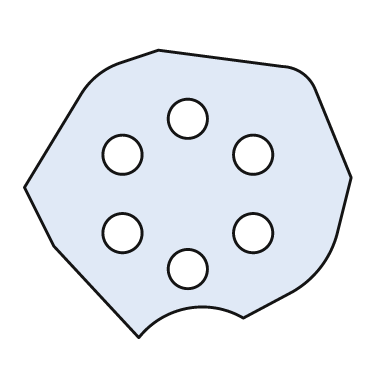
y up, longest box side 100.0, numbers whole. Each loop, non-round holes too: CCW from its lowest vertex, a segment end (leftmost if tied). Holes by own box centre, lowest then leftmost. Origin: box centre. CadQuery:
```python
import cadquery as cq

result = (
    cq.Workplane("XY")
    .moveTo(-15.0, -44.0)
    .threePointArc((0.0, -35.0), (17.0, -38.0))
    .lineTo(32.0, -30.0)
    .threePointArc((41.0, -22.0), (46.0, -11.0))
    .lineTo(50.0, 5.0)
    .lineTo(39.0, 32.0)
    .threePointArc((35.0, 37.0), (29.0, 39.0))
    .lineTo(-9.0, 44.0)
    .lineTo(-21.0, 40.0)
    .threePointArc((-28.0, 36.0), (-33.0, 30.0))
    .lineTo(-50.0, 2.0)
    .lineTo(-41.0, -16.0)
    .close()
    .moveTo(0.0, -23.0)
    .circle(6.0)
    .moveTo(-20.0, -12.0)
    .circle(6.0)
    .moveTo(20.0, -12.0)
    .circle(6.0)
    .moveTo(-20.0, 12.0)
    .circle(6.0)
    .moveTo(20.0, 12.0)
    .circle(6.0)
    .moveTo(0.0, 23.0)
    .circle(6.0)
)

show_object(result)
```